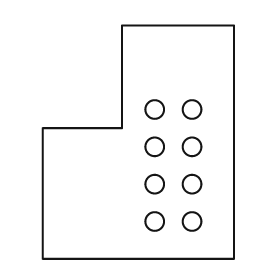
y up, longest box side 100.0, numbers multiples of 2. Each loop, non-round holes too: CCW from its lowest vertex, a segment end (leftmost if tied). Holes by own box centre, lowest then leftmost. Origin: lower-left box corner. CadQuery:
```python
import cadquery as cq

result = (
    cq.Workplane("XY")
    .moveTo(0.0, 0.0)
    .lineTo(82.0, 0.0)
    .lineTo(82.0, 100.0)
    .lineTo(34.0, 100.0)
    .lineTo(34.0, 56.0)
    .lineTo(0.0, 56.0)
    .close()
    .moveTo(48.0, 16.0)
    .circle(4.0)
    .moveTo(64.0, 16.0)
    .circle(4.0)
    .moveTo(48.0, 32.0)
    .circle(4.0)
    .moveTo(64.0, 32.0)
    .circle(4.0)
    .moveTo(48.0, 48.0)
    .circle(4.0)
    .moveTo(64.0, 48.0)
    .circle(4.0)
    .moveTo(48.0, 64.0)
    .circle(4.0)
    .moveTo(64.0, 64.0)
    .circle(4.0)
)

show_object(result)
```